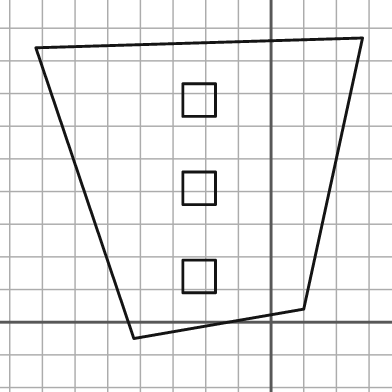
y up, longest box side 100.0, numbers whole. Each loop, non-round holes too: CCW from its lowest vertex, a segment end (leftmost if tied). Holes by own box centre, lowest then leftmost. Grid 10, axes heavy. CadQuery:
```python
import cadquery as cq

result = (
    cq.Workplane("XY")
    .moveTo(-42.0, -5.0)
    .lineTo(10.0, 4.0)
    .lineTo(28.0, 87.0)
    .lineTo(-72.0, 84.0)
    .close()
    .moveTo(-27.0, 9.0)
    .lineTo(-17.0, 9.0)
    .lineTo(-17.0, 19.0)
    .lineTo(-27.0, 19.0)
    .close()
    .moveTo(-27.0, 36.0)
    .lineTo(-17.0, 36.0)
    .lineTo(-17.0, 46.0)
    .lineTo(-27.0, 46.0)
    .close()
    .moveTo(-27.0, 63.0)
    .lineTo(-17.0, 63.0)
    .lineTo(-17.0, 73.0)
    .lineTo(-27.0, 73.0)
    .close()
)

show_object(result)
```